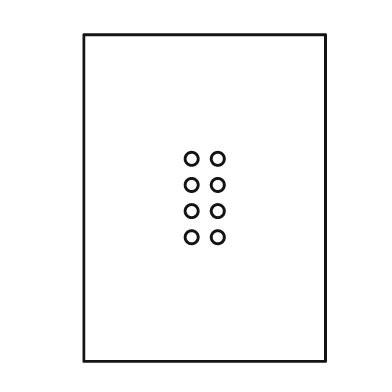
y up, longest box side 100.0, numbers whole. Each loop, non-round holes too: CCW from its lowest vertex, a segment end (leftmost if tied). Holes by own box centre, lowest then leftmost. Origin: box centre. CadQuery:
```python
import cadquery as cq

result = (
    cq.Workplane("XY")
    .moveTo(-37.0, -50.0)
    .lineTo(37.0, -50.0)
    .lineTo(37.0, 50.0)
    .lineTo(-37.0, 50.0)
    .close()
    .moveTo(-4.0, -12.0)
    .circle(2.0)
    .moveTo(4.0, -12.0)
    .circle(2.0)
    .moveTo(-4.0, -4.0)
    .circle(2.0)
    .moveTo(4.0, -4.0)
    .circle(2.0)
    .moveTo(-4.0, 4.0)
    .circle(2.0)
    .moveTo(4.0, 4.0)
    .circle(2.0)
    .moveTo(-4.0, 12.0)
    .circle(2.0)
    .moveTo(4.0, 12.0)
    .circle(2.0)
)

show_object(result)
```